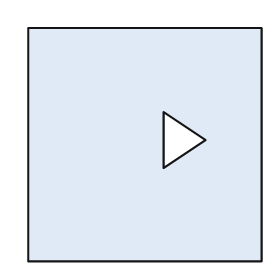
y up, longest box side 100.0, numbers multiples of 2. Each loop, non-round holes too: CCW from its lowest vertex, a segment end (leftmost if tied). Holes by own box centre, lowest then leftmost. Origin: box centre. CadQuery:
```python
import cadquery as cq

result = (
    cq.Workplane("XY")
    .moveTo(-50.0, -50.0)
    .lineTo(50.0, -50.0)
    .lineTo(50.0, 50.0)
    .lineTo(-50.0, 50.0)
    .close()
    .moveTo(8.0, -10.0)
    .lineTo(26.0, 2.0)
    .lineTo(8.0, 14.0)
    .close()
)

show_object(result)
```